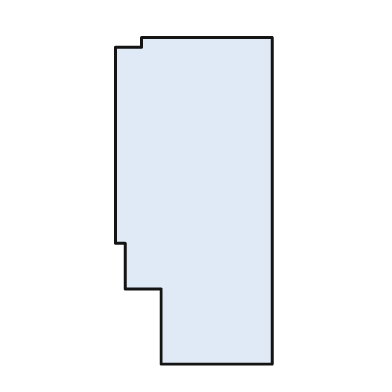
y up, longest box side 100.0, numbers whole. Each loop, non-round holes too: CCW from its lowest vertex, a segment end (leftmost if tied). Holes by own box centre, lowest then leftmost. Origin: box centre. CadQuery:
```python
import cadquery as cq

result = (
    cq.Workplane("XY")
    .moveTo(-10.0, -50.0)
    .lineTo(24.0, -50.0)
    .lineTo(24.0, 50.0)
    .lineTo(-16.0, 50.0)
    .lineTo(-16.0, 47.0)
    .lineTo(-24.0, 47.0)
    .lineTo(-24.0, -13.0)
    .lineTo(-21.0, -13.0)
    .lineTo(-21.0, -27.0)
    .lineTo(-10.0, -27.0)
    .close()
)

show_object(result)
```